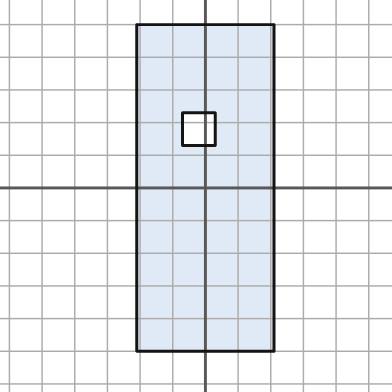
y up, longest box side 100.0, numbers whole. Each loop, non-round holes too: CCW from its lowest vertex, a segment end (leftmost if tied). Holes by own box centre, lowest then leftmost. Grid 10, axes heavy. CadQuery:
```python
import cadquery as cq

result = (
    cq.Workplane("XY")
    .moveTo(-21.0, -50.0)
    .lineTo(21.0, -50.0)
    .lineTo(21.0, 50.0)
    .lineTo(-21.0, 50.0)
    .close()
    .moveTo(-7.0, 13.0)
    .lineTo(3.0, 13.0)
    .lineTo(3.0, 23.0)
    .lineTo(-7.0, 23.0)
    .close()
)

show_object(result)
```